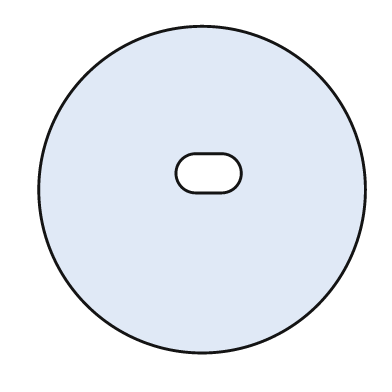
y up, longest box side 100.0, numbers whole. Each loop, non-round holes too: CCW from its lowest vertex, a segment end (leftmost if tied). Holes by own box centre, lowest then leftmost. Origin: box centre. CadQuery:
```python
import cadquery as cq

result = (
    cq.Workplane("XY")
    .moveTo(0.0, 0.0)
    .circle(50.0)
    .moveTo(-2.0, -1.0)
    .lineTo(6.0, -1.0)
    .threePointArc((12.0, 5.0), (6.0, 11.0))
    .lineTo(-2.0, 11.0)
    .threePointArc((-8.0, 5.0), (-2.0, -1.0))
    .close()
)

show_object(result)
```